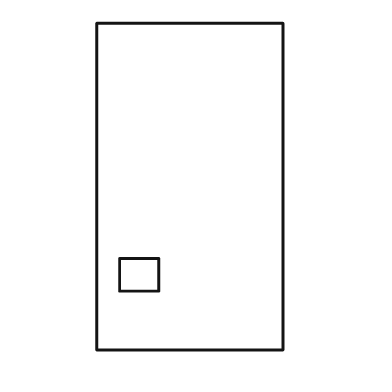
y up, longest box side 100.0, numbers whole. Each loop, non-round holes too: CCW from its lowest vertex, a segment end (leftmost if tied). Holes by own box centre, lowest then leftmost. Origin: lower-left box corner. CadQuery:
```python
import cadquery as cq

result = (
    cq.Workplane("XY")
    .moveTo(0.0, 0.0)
    .lineTo(57.0, 0.0)
    .lineTo(57.0, 100.0)
    .lineTo(0.0, 100.0)
    .close()
    .moveTo(7.0, 18.0)
    .lineTo(19.0, 18.0)
    .lineTo(19.0, 28.0)
    .lineTo(7.0, 28.0)
    .close()
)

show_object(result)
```